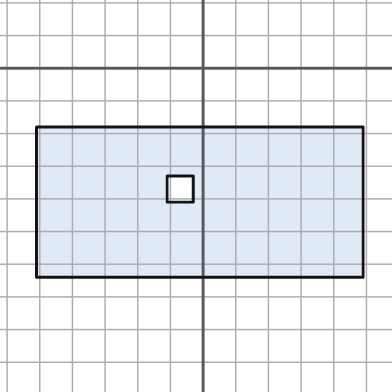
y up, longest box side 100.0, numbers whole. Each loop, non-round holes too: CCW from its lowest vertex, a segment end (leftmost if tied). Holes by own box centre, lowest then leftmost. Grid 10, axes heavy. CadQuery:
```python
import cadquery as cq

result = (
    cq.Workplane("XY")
    .moveTo(-51.0, -64.0)
    .lineTo(49.0, -64.0)
    .lineTo(49.0, -18.0)
    .lineTo(-51.0, -18.0)
    .close()
    .moveTo(-11.0, -41.0)
    .lineTo(-3.0, -41.0)
    .lineTo(-3.0, -33.0)
    .lineTo(-11.0, -33.0)
    .close()
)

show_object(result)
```